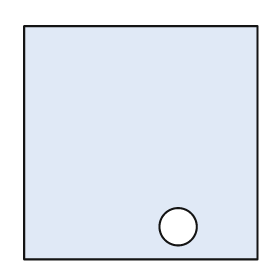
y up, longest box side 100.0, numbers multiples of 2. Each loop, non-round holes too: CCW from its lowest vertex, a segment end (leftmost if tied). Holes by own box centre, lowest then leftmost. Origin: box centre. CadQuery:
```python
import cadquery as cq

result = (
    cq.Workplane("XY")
    .moveTo(-50.0, -50.0)
    .lineTo(50.0, -50.0)
    .lineTo(50.0, 50.0)
    .lineTo(-50.0, 50.0)
    .close()
    .moveTo(16.0, -36.0)
    .circle(8.0)
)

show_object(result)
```